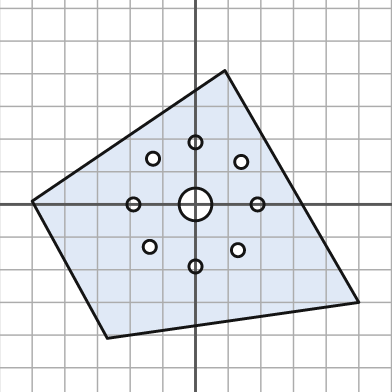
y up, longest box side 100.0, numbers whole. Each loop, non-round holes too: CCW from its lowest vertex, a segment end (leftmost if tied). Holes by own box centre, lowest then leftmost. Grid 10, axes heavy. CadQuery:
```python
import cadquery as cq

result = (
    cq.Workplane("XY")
    .moveTo(-27.0, -41.0)
    .lineTo(50.0, -30.0)
    .lineTo(9.0, 41.0)
    .lineTo(-50.0, 1.0)
    .close()
    .moveTo(0.0, -19.0)
    .circle(2.0)
    .moveTo(13.0, -14.0)
    .circle(2.0)
    .moveTo(-14.0, -13.0)
    .circle(2.0)
    .moveTo(-19.0, 0.0)
    .circle(2.0)
    .moveTo(0.0, 0.0)
    .circle(5.0)
    .moveTo(19.0, 0.0)
    .circle(2.0)
    .moveTo(14.0, 13.0)
    .circle(2.0)
    .moveTo(-13.0, 14.0)
    .circle(2.0)
    .moveTo(0.0, 19.0)
    .circle(2.0)
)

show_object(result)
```